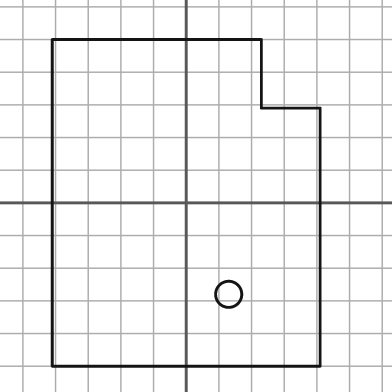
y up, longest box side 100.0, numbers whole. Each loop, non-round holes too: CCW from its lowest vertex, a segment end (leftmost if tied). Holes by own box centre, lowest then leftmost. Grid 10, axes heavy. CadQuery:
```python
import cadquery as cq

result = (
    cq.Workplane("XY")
    .moveTo(-41.0, -50.0)
    .lineTo(41.0, -50.0)
    .lineTo(41.0, 29.0)
    .lineTo(23.0, 29.0)
    .lineTo(23.0, 50.0)
    .lineTo(-41.0, 50.0)
    .close()
    .moveTo(13.0, -28.0)
    .circle(4.0)
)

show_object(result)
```